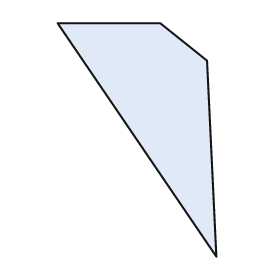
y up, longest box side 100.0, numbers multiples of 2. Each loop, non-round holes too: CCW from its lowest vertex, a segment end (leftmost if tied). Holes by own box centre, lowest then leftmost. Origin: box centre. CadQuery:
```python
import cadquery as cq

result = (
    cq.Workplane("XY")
    .moveTo(34.0, -50.0)
    .lineTo(30.0, 34.0)
    .lineTo(10.0, 50.0)
    .lineTo(-34.0, 50.0)
    .close()
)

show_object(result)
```